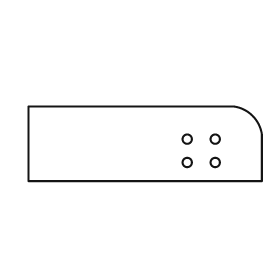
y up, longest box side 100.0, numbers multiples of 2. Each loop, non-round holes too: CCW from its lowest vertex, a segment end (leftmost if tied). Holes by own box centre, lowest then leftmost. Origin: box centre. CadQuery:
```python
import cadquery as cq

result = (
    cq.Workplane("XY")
    .moveTo(-50.0, -16.0)
    .lineTo(50.0, -16.0)
    .lineTo(50.0, 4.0)
    .threePointArc((46.0, 12.0), (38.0, 16.0))
    .lineTo(-50.0, 16.0)
    .close()
    .moveTo(18.0, -8.0)
    .circle(2.0)
    .moveTo(30.0, -8.0)
    .circle(2.0)
    .moveTo(18.0, 2.0)
    .circle(2.0)
    .moveTo(30.0, 2.0)
    .circle(2.0)
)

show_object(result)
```